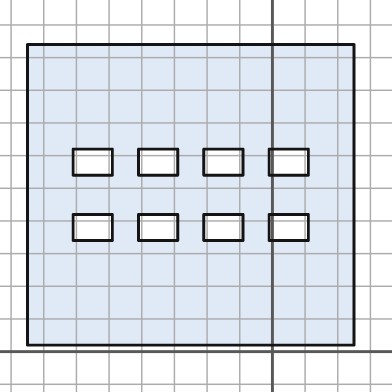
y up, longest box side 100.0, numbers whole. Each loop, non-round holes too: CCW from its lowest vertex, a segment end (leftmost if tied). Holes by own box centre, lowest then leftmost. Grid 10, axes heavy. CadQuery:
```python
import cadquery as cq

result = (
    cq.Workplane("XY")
    .moveTo(-75.0, 2.0)
    .lineTo(25.0, 2.0)
    .lineTo(25.0, 94.0)
    .lineTo(-75.0, 94.0)
    .close()
    .moveTo(-61.0, 34.0)
    .lineTo(-49.0, 34.0)
    .lineTo(-49.0, 42.0)
    .lineTo(-61.0, 42.0)
    .close()
    .moveTo(-41.0, 34.0)
    .lineTo(-29.0, 34.0)
    .lineTo(-29.0, 42.0)
    .lineTo(-41.0, 42.0)
    .close()
    .moveTo(-21.0, 34.0)
    .lineTo(-9.0, 34.0)
    .lineTo(-9.0, 42.0)
    .lineTo(-21.0, 42.0)
    .close()
    .moveTo(-1.0, 34.0)
    .lineTo(11.0, 34.0)
    .lineTo(11.0, 42.0)
    .lineTo(-1.0, 42.0)
    .close()
    .moveTo(-61.0, 54.0)
    .lineTo(-49.0, 54.0)
    .lineTo(-49.0, 62.0)
    .lineTo(-61.0, 62.0)
    .close()
    .moveTo(-41.0, 54.0)
    .lineTo(-29.0, 54.0)
    .lineTo(-29.0, 62.0)
    .lineTo(-41.0, 62.0)
    .close()
    .moveTo(-21.0, 54.0)
    .lineTo(-9.0, 54.0)
    .lineTo(-9.0, 62.0)
    .lineTo(-21.0, 62.0)
    .close()
    .moveTo(-1.0, 54.0)
    .lineTo(11.0, 54.0)
    .lineTo(11.0, 62.0)
    .lineTo(-1.0, 62.0)
    .close()
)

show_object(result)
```